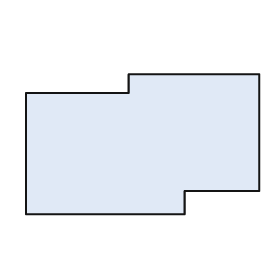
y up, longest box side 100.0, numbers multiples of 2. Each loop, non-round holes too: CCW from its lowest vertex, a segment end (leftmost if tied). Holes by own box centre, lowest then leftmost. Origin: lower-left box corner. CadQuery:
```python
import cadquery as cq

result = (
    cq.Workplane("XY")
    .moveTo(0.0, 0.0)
    .lineTo(68.0, 0.0)
    .lineTo(68.0, 10.0)
    .lineTo(100.0, 10.0)
    .lineTo(100.0, 60.0)
    .lineTo(44.0, 60.0)
    .lineTo(44.0, 52.0)
    .lineTo(0.0, 52.0)
    .close()
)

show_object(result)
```